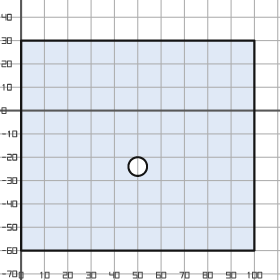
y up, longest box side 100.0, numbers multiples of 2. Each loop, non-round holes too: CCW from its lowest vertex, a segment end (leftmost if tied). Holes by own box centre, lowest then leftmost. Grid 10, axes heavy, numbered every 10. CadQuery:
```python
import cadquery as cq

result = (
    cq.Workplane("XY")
    .moveTo(0.0, -60.0)
    .lineTo(100.0, -60.0)
    .lineTo(100.0, 30.0)
    .lineTo(0.0, 30.0)
    .close()
    .moveTo(50.0, -24.0)
    .circle(4.0)
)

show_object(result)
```